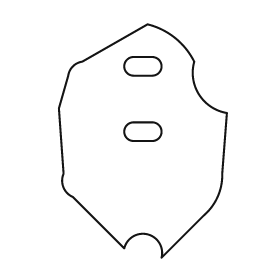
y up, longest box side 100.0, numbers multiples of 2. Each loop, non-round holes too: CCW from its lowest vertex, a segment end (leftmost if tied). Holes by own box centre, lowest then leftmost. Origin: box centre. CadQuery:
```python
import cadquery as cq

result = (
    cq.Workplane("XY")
    .moveTo(8.0, -50.0)
    .lineTo(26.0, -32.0)
    .threePointArc((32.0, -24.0), (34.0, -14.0))
    .lineTo(36.0, 12.0)
    .threePointArc((24.0, 20.0), (22.0, 34.0))
    .threePointArc((14.0, 44.0), (2.0, 50.0))
    .lineTo(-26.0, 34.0)
    .threePointArc((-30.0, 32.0), (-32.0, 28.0))
    .lineTo(-36.0, 14.0)
    .lineTo(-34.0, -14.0)
    .threePointArc((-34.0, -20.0), (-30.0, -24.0))
    .lineTo(-8.0, -46.0)
    .threePointArc((2.0, -40.0), (8.0, -50.0))
    .close()
    .moveTo(-4.0, 0.0)
    .lineTo(4.0, 0.0)
    .threePointArc((8.0, 4.0), (4.0, 8.0))
    .lineTo(-4.0, 8.0)
    .threePointArc((-8.0, 4.0), (-4.0, 0.0))
    .close()
    .moveTo(-4.0, 28.0)
    .lineTo(4.0, 28.0)
    .threePointArc((8.0, 32.0), (4.0, 36.0))
    .lineTo(-4.0, 36.0)
    .threePointArc((-8.0, 32.0), (-4.0, 28.0))
    .close()
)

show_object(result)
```